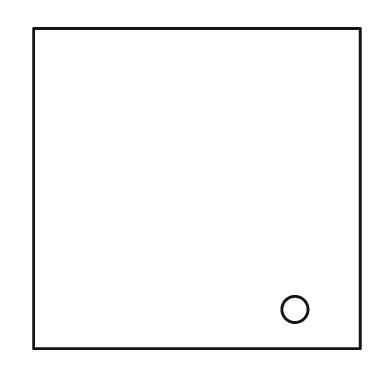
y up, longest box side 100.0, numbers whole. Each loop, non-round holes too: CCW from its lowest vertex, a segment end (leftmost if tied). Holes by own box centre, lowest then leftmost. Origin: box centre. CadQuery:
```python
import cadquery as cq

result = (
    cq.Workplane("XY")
    .moveTo(-50.0, -49.0)
    .lineTo(50.0, -49.0)
    .lineTo(50.0, 49.0)
    .lineTo(-50.0, 49.0)
    .close()
    .moveTo(30.0, -37.0)
    .circle(4.0)
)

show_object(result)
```